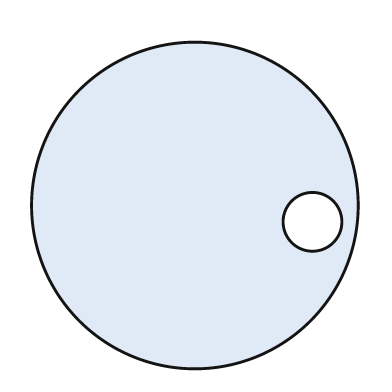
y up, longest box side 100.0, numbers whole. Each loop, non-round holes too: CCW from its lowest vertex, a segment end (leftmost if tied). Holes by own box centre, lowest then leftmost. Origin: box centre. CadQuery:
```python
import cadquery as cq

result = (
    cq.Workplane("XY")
    .moveTo(0.0, 0.0)
    .circle(50.0)
    .moveTo(36.0, -5.0)
    .circle(9.0)
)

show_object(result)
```